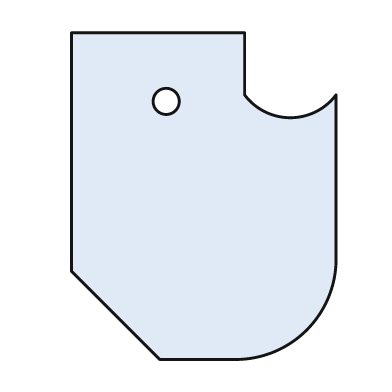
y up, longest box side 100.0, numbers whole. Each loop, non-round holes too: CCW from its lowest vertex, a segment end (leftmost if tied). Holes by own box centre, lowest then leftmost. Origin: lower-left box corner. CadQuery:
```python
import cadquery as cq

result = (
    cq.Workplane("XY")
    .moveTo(27.0, 0.0)
    .lineTo(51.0, 0.0)
    .threePointArc((72.0, 9.0), (81.0, 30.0))
    .lineTo(81.0, 81.0)
    .threePointArc((67.0, 74.0), (53.0, 81.0))
    .lineTo(53.0, 100.0)
    .lineTo(0.0, 100.0)
    .lineTo(0.0, 27.0)
    .close()
    .moveTo(29.0, 79.0)
    .circle(4.0)
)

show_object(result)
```